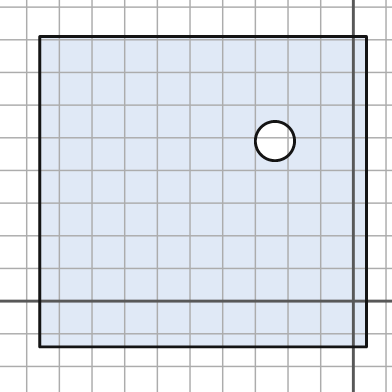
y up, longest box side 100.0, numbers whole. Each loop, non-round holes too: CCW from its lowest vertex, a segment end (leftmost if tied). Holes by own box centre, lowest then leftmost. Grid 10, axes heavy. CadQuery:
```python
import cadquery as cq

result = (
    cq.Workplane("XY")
    .moveTo(-96.0, -14.0)
    .lineTo(4.0, -14.0)
    .lineTo(4.0, 81.0)
    .lineTo(-96.0, 81.0)
    .close()
    .moveTo(-24.0, 49.0)
    .circle(6.0)
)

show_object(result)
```